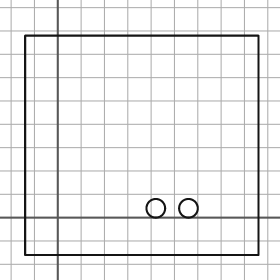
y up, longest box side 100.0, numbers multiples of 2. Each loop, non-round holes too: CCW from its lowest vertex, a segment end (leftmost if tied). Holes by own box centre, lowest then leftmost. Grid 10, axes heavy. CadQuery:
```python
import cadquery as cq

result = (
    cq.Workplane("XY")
    .moveTo(-14.0, -16.0)
    .lineTo(86.0, -16.0)
    .lineTo(86.0, 78.0)
    .lineTo(-14.0, 78.0)
    .close()
    .moveTo(42.0, 4.0)
    .circle(4.0)
    .moveTo(56.0, 4.0)
    .circle(4.0)
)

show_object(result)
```